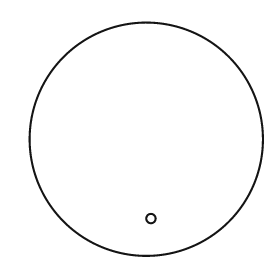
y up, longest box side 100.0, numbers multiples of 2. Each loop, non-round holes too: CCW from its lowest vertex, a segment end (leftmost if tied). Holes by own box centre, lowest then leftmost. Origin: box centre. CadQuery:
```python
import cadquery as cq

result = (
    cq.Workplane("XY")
    .moveTo(0.0, 0.0)
    .circle(50.0)
    .moveTo(2.0, -34.0)
    .circle(2.0)
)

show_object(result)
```